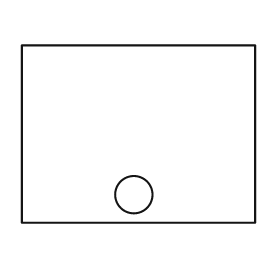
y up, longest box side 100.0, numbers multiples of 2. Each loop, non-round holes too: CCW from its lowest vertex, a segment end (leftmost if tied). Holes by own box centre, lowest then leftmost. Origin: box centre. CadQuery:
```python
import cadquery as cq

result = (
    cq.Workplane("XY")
    .moveTo(-50.0, -38.0)
    .lineTo(50.0, -38.0)
    .lineTo(50.0, 38.0)
    .lineTo(-50.0, 38.0)
    .close()
    .moveTo(-2.0, -26.0)
    .circle(8.0)
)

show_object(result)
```